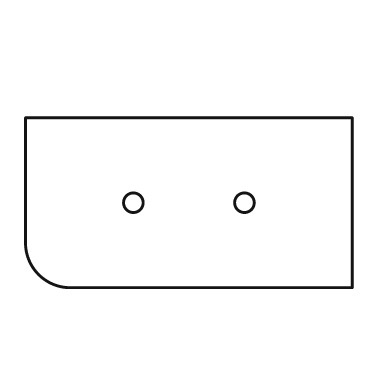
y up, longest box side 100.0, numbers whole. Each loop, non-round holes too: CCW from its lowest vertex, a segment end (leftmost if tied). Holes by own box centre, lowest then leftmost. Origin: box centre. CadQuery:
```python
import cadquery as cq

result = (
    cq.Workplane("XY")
    .moveTo(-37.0, -26.0)
    .lineTo(50.0, -26.0)
    .lineTo(50.0, 26.0)
    .lineTo(-50.0, 26.0)
    .lineTo(-50.0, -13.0)
    .threePointArc((-46.0, -22.0), (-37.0, -26.0))
    .close()
    .moveTo(-17.0, 0.0)
    .circle(3.0)
    .moveTo(17.0, 0.0)
    .circle(3.0)
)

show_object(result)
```